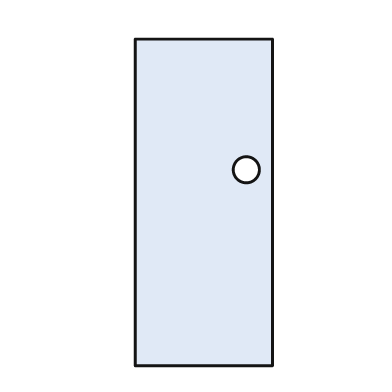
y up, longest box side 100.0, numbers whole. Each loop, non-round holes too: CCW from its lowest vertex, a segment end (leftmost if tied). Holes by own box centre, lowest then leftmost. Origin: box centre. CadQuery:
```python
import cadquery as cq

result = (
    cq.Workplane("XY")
    .moveTo(-21.0, -50.0)
    .lineTo(21.0, -50.0)
    .lineTo(21.0, 50.0)
    .lineTo(-21.0, 50.0)
    .close()
    .moveTo(13.0, 10.0)
    .circle(4.0)
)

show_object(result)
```